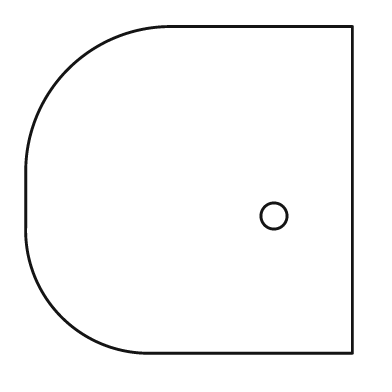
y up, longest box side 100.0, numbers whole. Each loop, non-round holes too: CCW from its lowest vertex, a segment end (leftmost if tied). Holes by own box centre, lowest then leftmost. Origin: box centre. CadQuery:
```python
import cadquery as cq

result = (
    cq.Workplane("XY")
    .moveTo(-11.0, -50.0)
    .lineTo(50.0, -50.0)
    .lineTo(50.0, 50.0)
    .lineTo(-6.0, 50.0)
    .threePointArc((-37.0, 37.0), (-50.0, 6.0))
    .lineTo(-50.0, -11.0)
    .threePointArc((-39.0, -39.0), (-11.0, -50.0))
    .close()
    .moveTo(26.0, -8.0)
    .circle(4.0)
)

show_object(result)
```